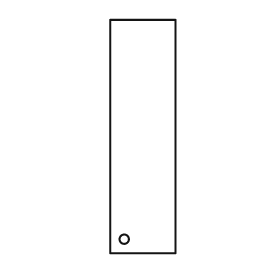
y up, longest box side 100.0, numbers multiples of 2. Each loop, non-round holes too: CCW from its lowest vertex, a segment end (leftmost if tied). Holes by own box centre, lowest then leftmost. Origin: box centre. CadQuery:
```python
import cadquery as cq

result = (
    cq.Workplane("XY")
    .moveTo(-14.0, -50.0)
    .lineTo(14.0, -50.0)
    .lineTo(14.0, 50.0)
    .lineTo(-14.0, 50.0)
    .close()
    .moveTo(-8.0, -44.0)
    .circle(2.0)
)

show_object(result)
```